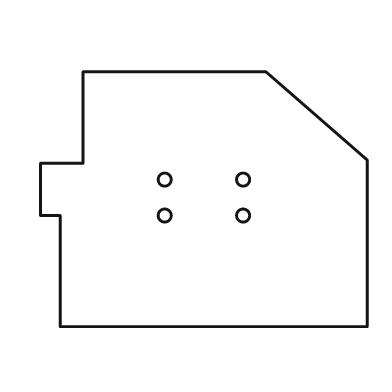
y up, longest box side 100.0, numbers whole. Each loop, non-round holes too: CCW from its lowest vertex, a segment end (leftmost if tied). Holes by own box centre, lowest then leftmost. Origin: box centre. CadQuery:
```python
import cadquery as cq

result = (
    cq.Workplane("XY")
    .moveTo(-44.0, -39.0)
    .lineTo(50.0, -39.0)
    .lineTo(50.0, 12.0)
    .lineTo(19.0, 39.0)
    .lineTo(-37.0, 39.0)
    .lineTo(-37.0, 11.0)
    .lineTo(-50.0, 11.0)
    .lineTo(-50.0, -5.0)
    .lineTo(-44.0, -5.0)
    .close()
    .moveTo(-12.0, -5.0)
    .circle(2.0)
    .moveTo(12.0, -5.0)
    .circle(2.0)
    .moveTo(-12.0, 6.0)
    .circle(2.0)
    .moveTo(12.0, 6.0)
    .circle(2.0)
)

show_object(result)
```